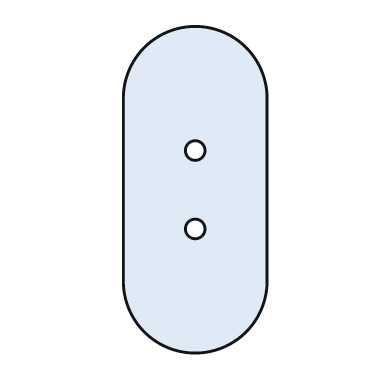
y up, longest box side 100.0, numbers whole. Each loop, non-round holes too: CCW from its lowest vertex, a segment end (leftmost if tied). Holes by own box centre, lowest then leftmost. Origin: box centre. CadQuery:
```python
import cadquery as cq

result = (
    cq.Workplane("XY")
    .moveTo(-22.0, -28.0)
    .threePointArc((0.0, -50.0), (22.0, -28.0))
    .lineTo(22.0, 28.0)
    .threePointArc((0.0, 50.0), (-22.0, 28.0))
    .close()
    .moveTo(0.0, -12.0)
    .circle(3.0)
    .moveTo(0.0, 12.0)
    .circle(3.0)
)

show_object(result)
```